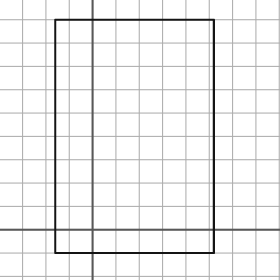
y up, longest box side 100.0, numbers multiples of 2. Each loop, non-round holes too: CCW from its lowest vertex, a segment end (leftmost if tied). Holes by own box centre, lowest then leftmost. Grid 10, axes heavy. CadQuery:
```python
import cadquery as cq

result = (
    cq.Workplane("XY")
    .moveTo(-16.0, -10.0)
    .lineTo(52.0, -10.0)
    .lineTo(52.0, 90.0)
    .lineTo(-16.0, 90.0)
    .close()
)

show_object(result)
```